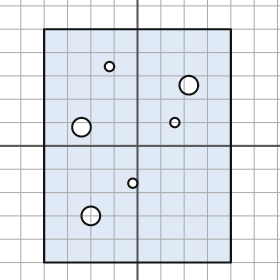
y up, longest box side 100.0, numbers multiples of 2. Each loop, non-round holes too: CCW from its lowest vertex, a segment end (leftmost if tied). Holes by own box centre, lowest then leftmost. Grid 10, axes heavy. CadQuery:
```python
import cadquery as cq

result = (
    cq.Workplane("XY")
    .moveTo(-40.0, -50.0)
    .lineTo(40.0, -50.0)
    .lineTo(40.0, 50.0)
    .lineTo(-40.0, 50.0)
    .close()
    .moveTo(-20.0, -30.0)
    .circle(4.0)
    .moveTo(-2.0, -16.0)
    .circle(2.0)
    .moveTo(-24.0, 8.0)
    .circle(4.0)
    .moveTo(16.0, 10.0)
    .circle(2.0)
    .moveTo(22.0, 26.0)
    .circle(4.0)
    .moveTo(-12.0, 34.0)
    .circle(2.0)
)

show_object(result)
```